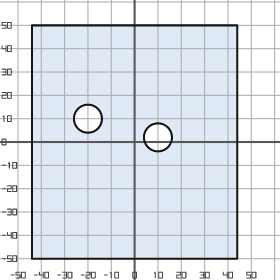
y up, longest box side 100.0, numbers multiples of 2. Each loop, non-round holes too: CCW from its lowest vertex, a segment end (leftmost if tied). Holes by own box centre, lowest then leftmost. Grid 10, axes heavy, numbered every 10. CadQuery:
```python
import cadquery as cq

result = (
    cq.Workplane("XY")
    .moveTo(-44.0, -50.0)
    .lineTo(44.0, -50.0)
    .lineTo(44.0, 50.0)
    .lineTo(-44.0, 50.0)
    .close()
    .moveTo(10.0, 2.0)
    .circle(6.0)
    .moveTo(-20.0, 10.0)
    .circle(6.0)
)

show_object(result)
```